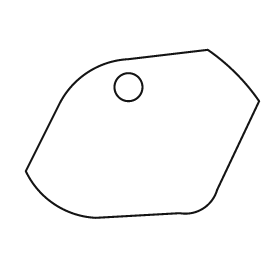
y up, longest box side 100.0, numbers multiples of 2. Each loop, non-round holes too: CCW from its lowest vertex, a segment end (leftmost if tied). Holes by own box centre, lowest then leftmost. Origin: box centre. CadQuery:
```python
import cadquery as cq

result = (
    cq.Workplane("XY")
    .moveTo(-20.0, -36.0)
    .lineTo(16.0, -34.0)
    .threePointArc((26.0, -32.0), (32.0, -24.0))
    .lineTo(50.0, 14.0)
    .threePointArc((40.0, 26.0), (28.0, 36.0))
    .lineTo(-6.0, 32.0)
    .threePointArc((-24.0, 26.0), (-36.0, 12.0))
    .lineTo(-50.0, -16.0)
    .threePointArc((-38.0, -30.0), (-20.0, -36.0))
    .close()
    .moveTo(-6.0, 20.0)
    .circle(6.0)
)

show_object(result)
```